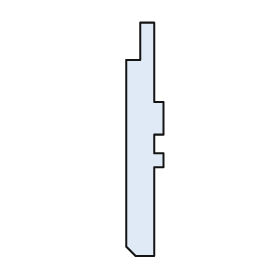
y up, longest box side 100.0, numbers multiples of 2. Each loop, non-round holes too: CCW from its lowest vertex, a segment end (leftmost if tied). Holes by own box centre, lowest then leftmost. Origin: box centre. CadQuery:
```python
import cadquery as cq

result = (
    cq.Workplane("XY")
    .moveTo(-4.0, -50.0)
    .lineTo(4.0, -50.0)
    .lineTo(4.0, -12.0)
    .lineTo(8.0, -12.0)
    .lineTo(8.0, -6.0)
    .lineTo(4.0, -6.0)
    .lineTo(4.0, 2.0)
    .lineTo(8.0, 2.0)
    .lineTo(8.0, 16.0)
    .lineTo(4.0, 16.0)
    .lineTo(4.0, 50.0)
    .lineTo(-2.0, 50.0)
    .lineTo(-2.0, 34.0)
    .lineTo(-8.0, 34.0)
    .lineTo(-8.0, -46.0)
    .close()
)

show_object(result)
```